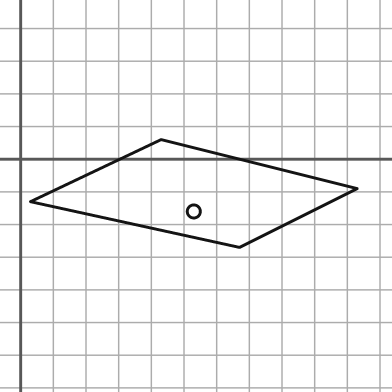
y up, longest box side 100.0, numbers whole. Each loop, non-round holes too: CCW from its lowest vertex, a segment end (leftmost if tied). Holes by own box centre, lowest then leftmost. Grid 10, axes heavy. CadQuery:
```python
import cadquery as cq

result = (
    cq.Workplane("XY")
    .moveTo(67.0, -27.0)
    .lineTo(103.0, -9.0)
    .lineTo(43.0, 6.0)
    .lineTo(3.0, -13.0)
    .close()
    .moveTo(53.0, -16.0)
    .circle(2.0)
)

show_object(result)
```